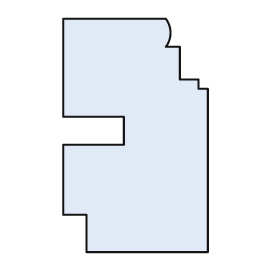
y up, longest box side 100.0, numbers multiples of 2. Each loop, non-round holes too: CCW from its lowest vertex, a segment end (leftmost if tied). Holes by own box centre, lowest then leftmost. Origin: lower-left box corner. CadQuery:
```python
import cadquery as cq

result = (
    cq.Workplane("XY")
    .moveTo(10.0, 0.0)
    .lineTo(62.0, 0.0)
    .lineTo(62.0, 70.0)
    .lineTo(58.0, 70.0)
    .lineTo(58.0, 74.0)
    .lineTo(50.0, 74.0)
    .lineTo(50.0, 88.0)
    .lineTo(44.0, 88.0)
    .threePointArc((46.0, 94.0), (44.0, 100.0))
    .lineTo(0.0, 100.0)
    .lineTo(0.0, 58.0)
    .lineTo(26.0, 58.0)
    .lineTo(26.0, 46.0)
    .lineTo(0.0, 46.0)
    .lineTo(0.0, 16.0)
    .lineTo(10.0, 16.0)
    .close()
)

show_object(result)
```